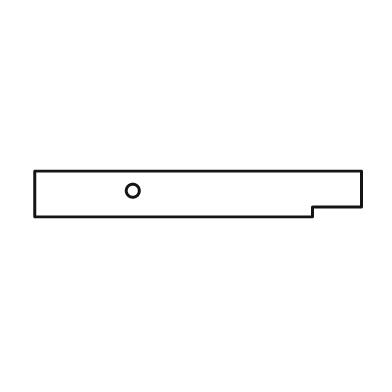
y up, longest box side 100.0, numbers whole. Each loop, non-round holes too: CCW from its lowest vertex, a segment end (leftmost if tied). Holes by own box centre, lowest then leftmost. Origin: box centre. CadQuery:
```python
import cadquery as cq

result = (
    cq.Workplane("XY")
    .moveTo(-50.0, -7.0)
    .lineTo(35.0, -7.0)
    .lineTo(35.0, -4.0)
    .lineTo(50.0, -4.0)
    .lineTo(50.0, 7.0)
    .lineTo(-50.0, 7.0)
    .close()
    .moveTo(-20.0, 1.0)
    .circle(2.0)
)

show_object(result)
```